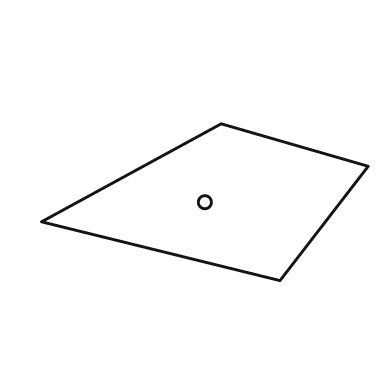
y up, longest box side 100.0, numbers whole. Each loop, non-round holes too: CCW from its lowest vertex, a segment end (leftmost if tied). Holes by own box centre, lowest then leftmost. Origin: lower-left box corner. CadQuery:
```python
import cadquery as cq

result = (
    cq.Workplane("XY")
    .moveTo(73.0, 0.0)
    .lineTo(100.0, 35.0)
    .lineTo(55.0, 48.0)
    .lineTo(0.0, 18.0)
    .close()
    .moveTo(50.0, 24.0)
    .circle(2.0)
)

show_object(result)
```